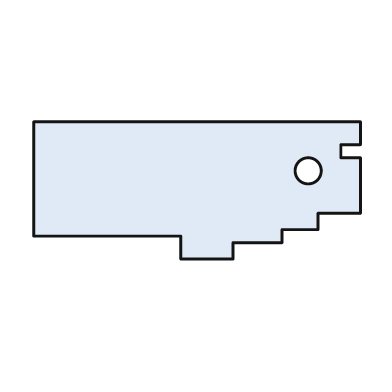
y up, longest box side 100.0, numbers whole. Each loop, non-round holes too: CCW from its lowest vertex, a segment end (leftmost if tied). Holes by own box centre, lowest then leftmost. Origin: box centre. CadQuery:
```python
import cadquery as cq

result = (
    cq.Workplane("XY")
    .moveTo(-5.0, -21.0)
    .lineTo(11.0, -21.0)
    .lineTo(11.0, -16.0)
    .lineTo(26.0, -16.0)
    .lineTo(26.0, -12.0)
    .lineTo(37.0, -12.0)
    .lineTo(37.0, -7.0)
    .lineTo(50.0, -7.0)
    .lineTo(50.0, 10.0)
    .lineTo(44.0, 10.0)
    .lineTo(44.0, 14.0)
    .lineTo(50.0, 14.0)
    .lineTo(50.0, 21.0)
    .lineTo(-50.0, 21.0)
    .lineTo(-50.0, -14.0)
    .lineTo(-5.0, -14.0)
    .close()
    .moveTo(34.0, 6.0)
    .circle(4.0)
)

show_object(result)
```